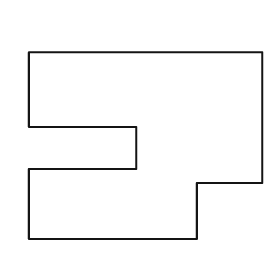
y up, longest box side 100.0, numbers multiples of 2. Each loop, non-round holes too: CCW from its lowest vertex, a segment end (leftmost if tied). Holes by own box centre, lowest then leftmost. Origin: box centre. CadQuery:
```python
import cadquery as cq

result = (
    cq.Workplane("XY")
    .moveTo(-50.0, -40.0)
    .lineTo(22.0, -40.0)
    .lineTo(22.0, -16.0)
    .lineTo(50.0, -16.0)
    .lineTo(50.0, 40.0)
    .lineTo(-50.0, 40.0)
    .lineTo(-50.0, 8.0)
    .lineTo(-4.0, 8.0)
    .lineTo(-4.0, -10.0)
    .lineTo(-50.0, -10.0)
    .close()
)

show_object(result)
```